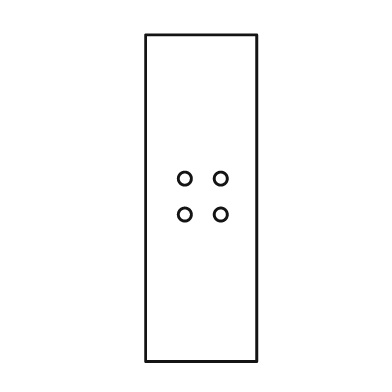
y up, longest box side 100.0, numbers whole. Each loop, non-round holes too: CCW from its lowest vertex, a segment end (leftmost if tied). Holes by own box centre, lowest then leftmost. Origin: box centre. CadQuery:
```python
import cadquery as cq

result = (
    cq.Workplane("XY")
    .moveTo(-17.0, -50.0)
    .lineTo(17.0, -50.0)
    .lineTo(17.0, 50.0)
    .lineTo(-17.0, 50.0)
    .close()
    .moveTo(-5.0, -5.0)
    .circle(2.0)
    .moveTo(6.0, -5.0)
    .circle(2.0)
    .moveTo(-5.0, 6.0)
    .circle(2.0)
    .moveTo(6.0, 6.0)
    .circle(2.0)
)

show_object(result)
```